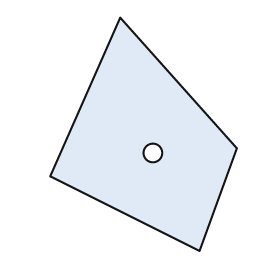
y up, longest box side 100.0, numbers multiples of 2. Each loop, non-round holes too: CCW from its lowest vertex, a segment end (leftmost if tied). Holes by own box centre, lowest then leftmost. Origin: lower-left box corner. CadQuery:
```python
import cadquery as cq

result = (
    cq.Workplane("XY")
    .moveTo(64.0, 0.0)
    .lineTo(80.0, 44.0)
    .lineTo(30.0, 100.0)
    .lineTo(0.0, 32.0)
    .close()
    .moveTo(44.0, 42.0)
    .circle(4.0)
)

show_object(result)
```